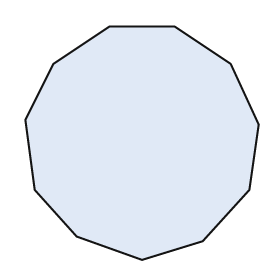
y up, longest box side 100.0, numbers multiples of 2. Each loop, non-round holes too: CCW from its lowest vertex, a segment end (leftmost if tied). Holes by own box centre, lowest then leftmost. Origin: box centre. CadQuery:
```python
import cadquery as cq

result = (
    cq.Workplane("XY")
    .moveTo(0.0, -50.0)
    .lineTo(26.0, -42.0)
    .lineTo(46.0, -20.0)
    .lineTo(50.0, 8.0)
    .lineTo(38.0, 34.0)
    .lineTo(14.0, 50.0)
    .lineTo(-14.0, 50.0)
    .lineTo(-38.0, 34.0)
    .lineTo(-50.0, 10.0)
    .lineTo(-46.0, -20.0)
    .lineTo(-28.0, -40.0)
    .close()
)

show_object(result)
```